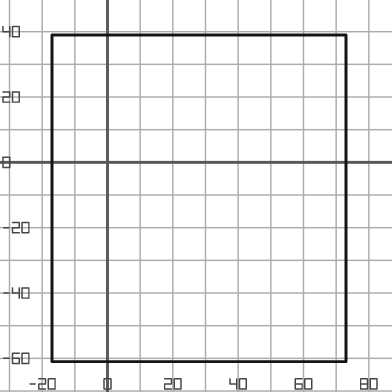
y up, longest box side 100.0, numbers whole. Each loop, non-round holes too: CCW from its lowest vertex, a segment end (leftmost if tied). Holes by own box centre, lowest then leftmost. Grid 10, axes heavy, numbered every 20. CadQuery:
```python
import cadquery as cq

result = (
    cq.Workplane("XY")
    .moveTo(-17.0, -61.0)
    .lineTo(73.0, -61.0)
    .lineTo(73.0, 39.0)
    .lineTo(-17.0, 39.0)
    .close()
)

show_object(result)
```